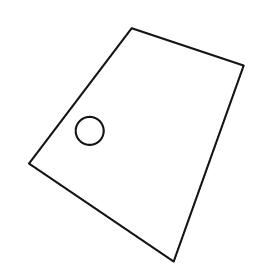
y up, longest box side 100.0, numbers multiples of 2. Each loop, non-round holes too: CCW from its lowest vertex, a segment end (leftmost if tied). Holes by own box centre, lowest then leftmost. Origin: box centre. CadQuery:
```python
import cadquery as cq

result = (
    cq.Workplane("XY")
    .moveTo(16.0, -50.0)
    .lineTo(46.0, 34.0)
    .lineTo(-2.0, 50.0)
    .lineTo(-46.0, -8.0)
    .close()
    .moveTo(-20.0, 6.0)
    .circle(6.0)
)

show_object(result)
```